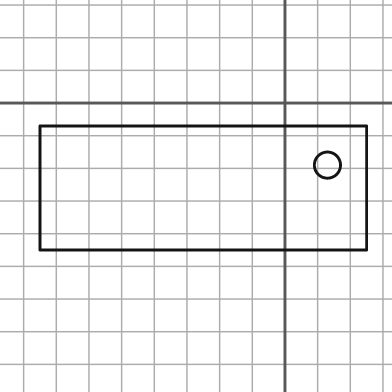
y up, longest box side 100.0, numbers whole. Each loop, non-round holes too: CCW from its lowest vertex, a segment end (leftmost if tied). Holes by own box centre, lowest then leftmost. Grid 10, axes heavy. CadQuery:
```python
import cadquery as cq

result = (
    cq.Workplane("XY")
    .moveTo(-75.0, -45.0)
    .lineTo(25.0, -45.0)
    .lineTo(25.0, -7.0)
    .lineTo(-75.0, -7.0)
    .close()
    .moveTo(13.0, -19.0)
    .circle(4.0)
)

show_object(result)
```